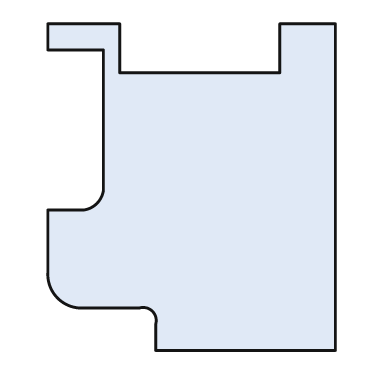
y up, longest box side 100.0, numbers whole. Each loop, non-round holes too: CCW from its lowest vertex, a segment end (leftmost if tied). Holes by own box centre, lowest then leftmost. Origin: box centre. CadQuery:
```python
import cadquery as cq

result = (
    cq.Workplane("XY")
    .moveTo(-11.0, -50.0)
    .lineTo(44.0, -50.0)
    .lineTo(44.0, 50.0)
    .lineTo(27.0, 50.0)
    .lineTo(27.0, 35.0)
    .lineTo(-22.0, 35.0)
    .lineTo(-22.0, 50.0)
    .lineTo(-44.0, 50.0)
    .lineTo(-44.0, 42.0)
    .lineTo(-27.0, 42.0)
    .lineTo(-27.0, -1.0)
    .threePointArc((-29.0, -5.0), (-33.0, -7.0))
    .lineTo(-44.0, -7.0)
    .lineTo(-44.0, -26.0)
    .threePointArc((-41.0, -34.0), (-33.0, -37.0))
    .lineTo(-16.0, -37.0)
    .threePointArc((-12.0, -38.0), (-11.0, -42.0))
    .close()
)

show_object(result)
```